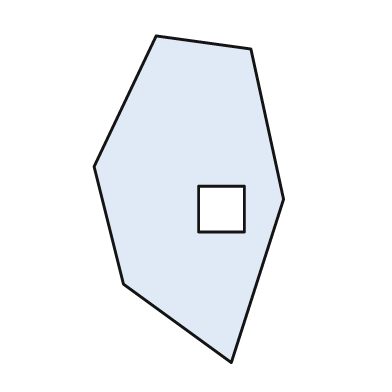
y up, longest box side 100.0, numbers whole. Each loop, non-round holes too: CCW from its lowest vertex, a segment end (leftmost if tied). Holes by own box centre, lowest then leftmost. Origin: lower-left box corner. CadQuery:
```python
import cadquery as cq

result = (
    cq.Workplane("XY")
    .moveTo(42.0, 0.0)
    .lineTo(58.0, 50.0)
    .lineTo(48.0, 96.0)
    .lineTo(19.0, 100.0)
    .lineTo(0.0, 60.0)
    .lineTo(9.0, 24.0)
    .close()
    .moveTo(32.0, 40.0)
    .lineTo(46.0, 40.0)
    .lineTo(46.0, 54.0)
    .lineTo(32.0, 54.0)
    .close()
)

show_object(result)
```